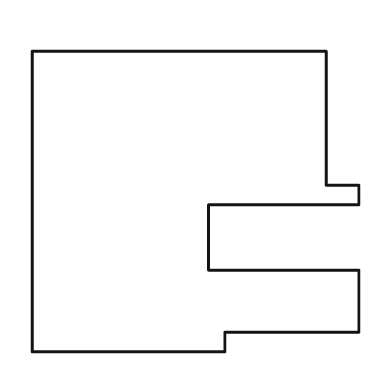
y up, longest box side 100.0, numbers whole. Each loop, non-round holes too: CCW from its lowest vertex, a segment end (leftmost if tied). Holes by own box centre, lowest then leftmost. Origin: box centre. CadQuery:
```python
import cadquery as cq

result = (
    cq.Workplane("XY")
    .moveTo(-50.0, -46.0)
    .lineTo(9.0, -46.0)
    .lineTo(9.0, -40.0)
    .lineTo(50.0, -40.0)
    .lineTo(50.0, -21.0)
    .lineTo(4.0, -21.0)
    .lineTo(4.0, -1.0)
    .lineTo(50.0, -1.0)
    .lineTo(50.0, 5.0)
    .lineTo(40.0, 5.0)
    .lineTo(40.0, 46.0)
    .lineTo(-50.0, 46.0)
    .close()
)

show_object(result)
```